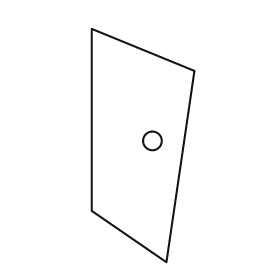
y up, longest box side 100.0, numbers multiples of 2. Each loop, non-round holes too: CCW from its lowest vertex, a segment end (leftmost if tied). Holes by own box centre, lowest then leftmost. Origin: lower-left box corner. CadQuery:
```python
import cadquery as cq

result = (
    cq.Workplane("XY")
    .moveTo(32.0, 0.0)
    .lineTo(44.0, 82.0)
    .lineTo(0.0, 100.0)
    .lineTo(0.0, 22.0)
    .close()
    .moveTo(26.0, 52.0)
    .circle(4.0)
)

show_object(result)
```